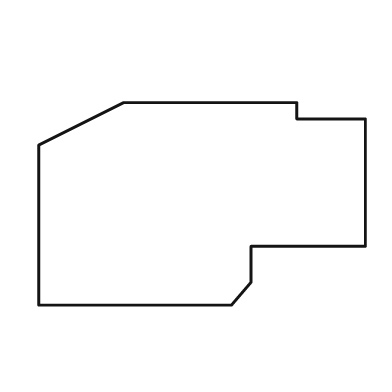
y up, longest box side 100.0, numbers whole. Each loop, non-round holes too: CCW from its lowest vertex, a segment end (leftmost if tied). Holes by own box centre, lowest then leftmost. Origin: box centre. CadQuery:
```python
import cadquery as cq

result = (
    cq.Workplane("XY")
    .moveTo(-50.0, -31.0)
    .lineTo(9.0, -31.0)
    .lineTo(15.0, -24.0)
    .lineTo(15.0, -13.0)
    .lineTo(50.0, -13.0)
    .lineTo(50.0, 26.0)
    .lineTo(29.0, 26.0)
    .lineTo(29.0, 31.0)
    .lineTo(-24.0, 31.0)
    .lineTo(-50.0, 18.0)
    .close()
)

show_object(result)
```